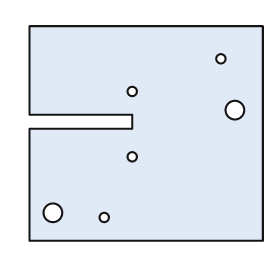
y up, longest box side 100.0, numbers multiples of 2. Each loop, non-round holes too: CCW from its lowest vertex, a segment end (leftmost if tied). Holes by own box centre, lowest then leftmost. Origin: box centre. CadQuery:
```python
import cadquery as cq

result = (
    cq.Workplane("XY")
    .moveTo(-50.0, -46.0)
    .lineTo(50.0, -46.0)
    .lineTo(50.0, 46.0)
    .lineTo(-50.0, 46.0)
    .lineTo(-50.0, 8.0)
    .lineTo(-6.0, 8.0)
    .lineTo(-6.0, 2.0)
    .lineTo(-50.0, 2.0)
    .close()
    .moveTo(-18.0, -36.0)
    .circle(2.0)
    .moveTo(-40.0, -34.0)
    .circle(4.0)
    .moveTo(-6.0, -10.0)
    .circle(2.0)
    .moveTo(38.0, 10.0)
    .circle(4.0)
    .moveTo(-6.0, 18.0)
    .circle(2.0)
    .moveTo(32.0, 32.0)
    .circle(2.0)
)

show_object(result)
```